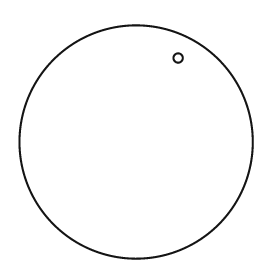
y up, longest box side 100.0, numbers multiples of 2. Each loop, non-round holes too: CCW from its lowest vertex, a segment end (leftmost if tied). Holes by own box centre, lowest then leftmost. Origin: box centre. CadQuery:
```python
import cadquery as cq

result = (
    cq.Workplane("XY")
    .moveTo(0.0, 0.0)
    .circle(50.0)
    .moveTo(18.0, 36.0)
    .circle(2.0)
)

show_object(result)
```